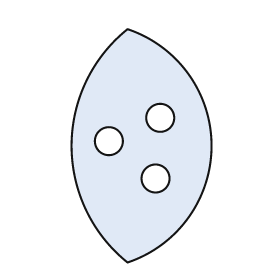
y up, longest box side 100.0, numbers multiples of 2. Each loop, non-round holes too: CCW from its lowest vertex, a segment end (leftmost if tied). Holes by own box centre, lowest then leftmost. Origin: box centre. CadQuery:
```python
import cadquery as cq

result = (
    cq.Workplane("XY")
    .moveTo(-6.0, -50.0)
    .threePointArc((30.0, 0.0), (-6.0, 50.0))
    .threePointArc((-30.0, 0.0), (-6.0, -50.0))
    .close()
    .moveTo(6.0, -14.0)
    .circle(6.0)
    .moveTo(-14.0, 2.0)
    .circle(6.0)
    .moveTo(8.0, 12.0)
    .circle(6.0)
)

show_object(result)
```